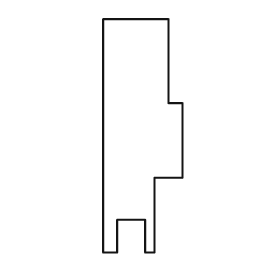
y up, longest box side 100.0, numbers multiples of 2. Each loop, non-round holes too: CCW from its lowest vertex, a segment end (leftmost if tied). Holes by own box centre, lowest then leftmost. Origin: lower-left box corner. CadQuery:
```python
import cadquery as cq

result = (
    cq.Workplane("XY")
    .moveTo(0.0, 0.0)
    .lineTo(6.0, 0.0)
    .lineTo(6.0, 14.0)
    .lineTo(18.0, 14.0)
    .lineTo(18.0, 0.0)
    .lineTo(22.0, 0.0)
    .lineTo(22.0, 32.0)
    .lineTo(34.0, 32.0)
    .lineTo(34.0, 64.0)
    .lineTo(28.0, 64.0)
    .lineTo(28.0, 100.0)
    .lineTo(0.0, 100.0)
    .close()
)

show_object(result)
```